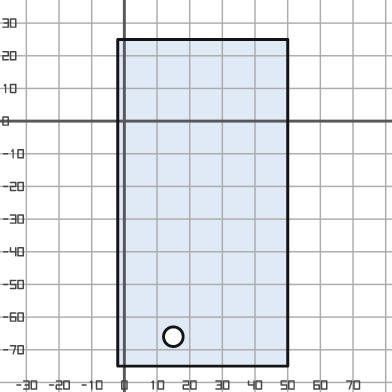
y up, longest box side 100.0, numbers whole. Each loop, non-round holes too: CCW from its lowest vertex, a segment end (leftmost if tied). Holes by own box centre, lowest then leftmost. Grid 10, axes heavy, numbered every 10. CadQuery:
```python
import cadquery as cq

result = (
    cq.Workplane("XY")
    .moveTo(-2.0, -75.0)
    .lineTo(50.0, -75.0)
    .lineTo(50.0, 25.0)
    .lineTo(-2.0, 25.0)
    .close()
    .moveTo(15.0, -66.0)
    .circle(3.0)
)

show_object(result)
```